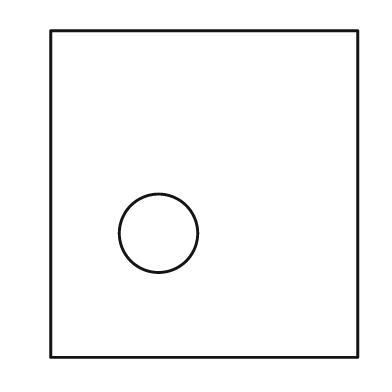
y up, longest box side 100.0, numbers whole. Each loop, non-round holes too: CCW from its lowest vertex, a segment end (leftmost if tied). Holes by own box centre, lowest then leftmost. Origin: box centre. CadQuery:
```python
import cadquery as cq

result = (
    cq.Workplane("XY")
    .moveTo(-47.0, -50.0)
    .lineTo(47.0, -50.0)
    .lineTo(47.0, 50.0)
    .lineTo(-47.0, 50.0)
    .close()
    .moveTo(-14.0, -12.0)
    .circle(12.0)
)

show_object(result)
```